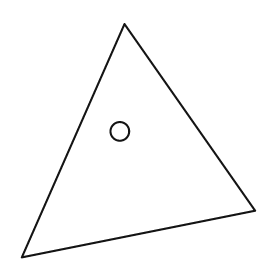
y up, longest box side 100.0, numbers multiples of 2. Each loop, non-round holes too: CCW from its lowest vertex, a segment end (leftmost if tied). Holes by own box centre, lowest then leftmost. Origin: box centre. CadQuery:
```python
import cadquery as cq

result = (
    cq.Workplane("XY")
    .moveTo(-50.0, -50.0)
    .lineTo(50.0, -30.0)
    .lineTo(-6.0, 50.0)
    .close()
    .moveTo(-8.0, 4.0)
    .circle(4.0)
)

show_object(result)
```